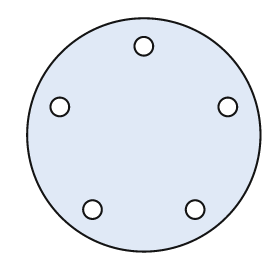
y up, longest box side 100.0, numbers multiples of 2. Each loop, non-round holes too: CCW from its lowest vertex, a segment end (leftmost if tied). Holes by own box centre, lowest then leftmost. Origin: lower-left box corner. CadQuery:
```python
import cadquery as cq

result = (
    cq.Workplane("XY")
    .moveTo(50.0, 50.0)
    .circle(50.0)
    .moveTo(28.0, 18.0)
    .circle(4.0)
    .moveTo(72.0, 18.0)
    .circle(4.0)
    .moveTo(14.0, 62.0)
    .circle(4.0)
    .moveTo(86.0, 62.0)
    .circle(4.0)
    .moveTo(50.0, 88.0)
    .circle(4.0)
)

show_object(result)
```